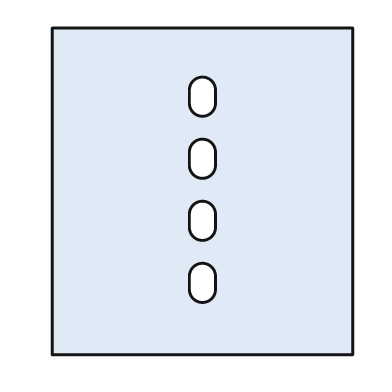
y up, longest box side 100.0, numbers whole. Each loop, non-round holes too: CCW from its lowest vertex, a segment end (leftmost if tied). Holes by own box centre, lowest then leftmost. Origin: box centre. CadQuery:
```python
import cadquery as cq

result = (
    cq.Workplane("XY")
    .moveTo(-46.0, -50.0)
    .lineTo(46.0, -50.0)
    .lineTo(46.0, 50.0)
    .lineTo(-46.0, 50.0)
    .close()
    .moveTo(-4.0, -30.0)
    .threePointArc((0.0, -34.0), (4.0, -30.0))
    .lineTo(4.0, -26.0)
    .threePointArc((0.0, -22.0), (-4.0, -26.0))
    .close()
    .moveTo(-4.0, -11.0)
    .threePointArc((0.0, -15.0), (4.0, -11.0))
    .lineTo(4.0, -7.0)
    .threePointArc((0.0, -3.0), (-4.0, -7.0))
    .close()
    .moveTo(-4.0, 8.0)
    .threePointArc((0.0, 4.0), (4.0, 8.0))
    .lineTo(4.0, 12.0)
    .threePointArc((0.0, 16.0), (-4.0, 12.0))
    .close()
    .moveTo(-4.0, 27.0)
    .threePointArc((0.0, 23.0), (4.0, 27.0))
    .lineTo(4.0, 31.0)
    .threePointArc((0.0, 35.0), (-4.0, 31.0))
    .close()
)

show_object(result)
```